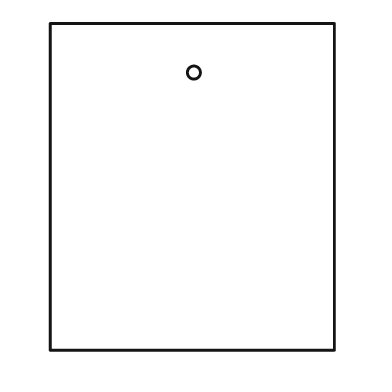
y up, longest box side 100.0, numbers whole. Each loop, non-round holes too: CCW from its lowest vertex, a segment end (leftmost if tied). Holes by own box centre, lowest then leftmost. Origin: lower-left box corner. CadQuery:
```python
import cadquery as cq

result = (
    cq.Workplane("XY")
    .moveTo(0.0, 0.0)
    .lineTo(87.0, 0.0)
    .lineTo(87.0, 100.0)
    .lineTo(0.0, 100.0)
    .close()
    .moveTo(44.0, 85.0)
    .circle(2.0)
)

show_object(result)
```